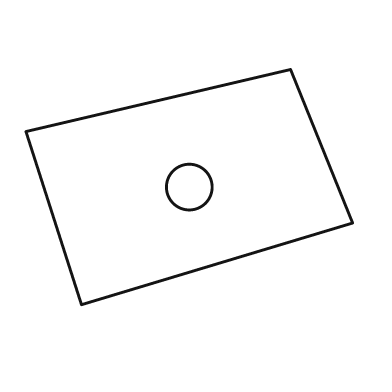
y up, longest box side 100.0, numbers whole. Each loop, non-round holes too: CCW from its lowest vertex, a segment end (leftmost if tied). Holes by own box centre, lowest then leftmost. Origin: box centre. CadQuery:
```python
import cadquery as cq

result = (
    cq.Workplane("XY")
    .moveTo(-33.0, -36.0)
    .lineTo(50.0, -11.0)
    .lineTo(31.0, 36.0)
    .lineTo(-50.0, 17.0)
    .close()
    .moveTo(0.0, 0.0)
    .circle(7.0)
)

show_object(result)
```